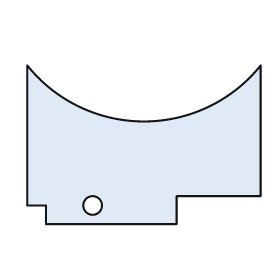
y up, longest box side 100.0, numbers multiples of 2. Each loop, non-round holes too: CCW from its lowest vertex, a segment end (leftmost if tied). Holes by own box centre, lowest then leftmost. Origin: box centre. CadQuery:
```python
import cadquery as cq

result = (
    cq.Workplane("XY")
    .moveTo(-42.0, -34.0)
    .lineTo(14.0, -34.0)
    .lineTo(14.0, -22.0)
    .lineTo(50.0, -22.0)
    .lineTo(50.0, 34.0)
    .threePointArc((0.0, 10.0), (-50.0, 34.0))
    .lineTo(-50.0, -26.0)
    .lineTo(-42.0, -26.0)
    .close()
    .moveTo(-22.0, -26.0)
    .circle(4.0)
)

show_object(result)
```